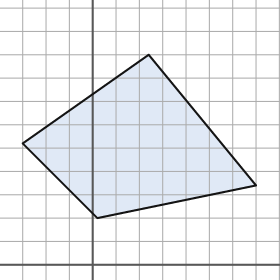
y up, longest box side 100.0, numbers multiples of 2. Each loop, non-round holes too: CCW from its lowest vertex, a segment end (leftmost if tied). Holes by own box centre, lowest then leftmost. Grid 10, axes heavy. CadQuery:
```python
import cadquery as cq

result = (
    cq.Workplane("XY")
    .moveTo(2.0, 20.0)
    .lineTo(70.0, 34.0)
    .lineTo(24.0, 90.0)
    .lineTo(-30.0, 52.0)
    .close()
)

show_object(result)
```